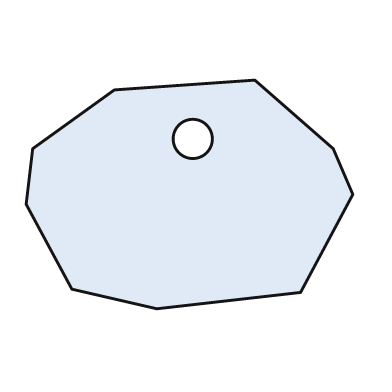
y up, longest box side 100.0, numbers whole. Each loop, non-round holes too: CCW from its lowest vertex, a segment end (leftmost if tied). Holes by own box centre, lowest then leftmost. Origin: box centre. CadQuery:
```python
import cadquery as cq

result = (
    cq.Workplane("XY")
    .moveTo(-10.0, -35.0)
    .lineTo(34.0, -30.0)
    .lineTo(50.0, 0.0)
    .lineTo(44.0, 14.0)
    .lineTo(20.0, 35.0)
    .lineTo(-23.0, 32.0)
    .lineTo(-48.0, 14.0)
    .lineTo(-50.0, -3.0)
    .lineTo(-36.0, -29.0)
    .close()
    .moveTo(1.0, 17.0)
    .circle(6.0)
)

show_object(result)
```